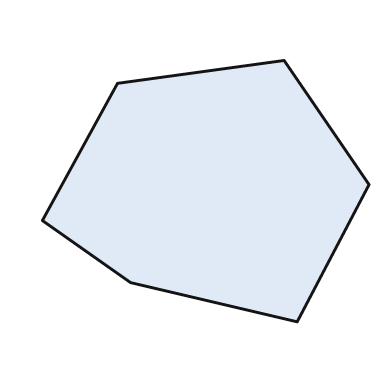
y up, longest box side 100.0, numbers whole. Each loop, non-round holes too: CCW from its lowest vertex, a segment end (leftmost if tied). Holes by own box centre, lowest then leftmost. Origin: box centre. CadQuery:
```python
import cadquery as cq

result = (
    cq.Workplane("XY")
    .moveTo(28.0, -40.0)
    .lineTo(50.0, 2.0)
    .lineTo(24.0, 40.0)
    .lineTo(-27.0, 33.0)
    .lineTo(-50.0, -9.0)
    .lineTo(-23.0, -28.0)
    .close()
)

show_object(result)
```